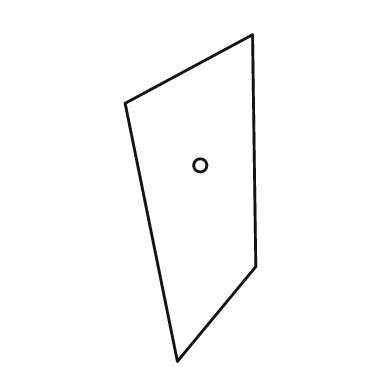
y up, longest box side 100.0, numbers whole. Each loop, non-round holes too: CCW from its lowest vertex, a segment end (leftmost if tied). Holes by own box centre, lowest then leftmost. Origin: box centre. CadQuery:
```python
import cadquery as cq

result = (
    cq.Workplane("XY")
    .moveTo(-4.0, -50.0)
    .lineTo(20.0, -21.0)
    .lineTo(19.0, 50.0)
    .lineTo(-20.0, 29.0)
    .close()
    .moveTo(3.0, 10.0)
    .circle(2.0)
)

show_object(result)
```